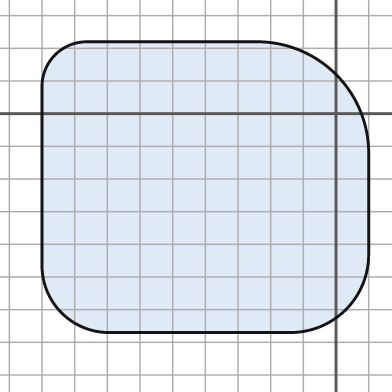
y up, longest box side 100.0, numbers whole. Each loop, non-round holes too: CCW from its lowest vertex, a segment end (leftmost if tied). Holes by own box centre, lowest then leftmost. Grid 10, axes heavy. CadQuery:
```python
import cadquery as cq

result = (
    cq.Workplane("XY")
    .moveTo(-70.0, -67.0)
    .lineTo(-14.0, -67.0)
    .threePointArc((3.0, -60.0), (10.0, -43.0))
    .lineTo(10.0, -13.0)
    .threePointArc((0.0, 12.0), (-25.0, 22.0))
    .lineTo(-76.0, 22.0)
    .threePointArc((-86.0, 18.0), (-90.0, 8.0))
    .lineTo(-90.0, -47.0)
    .threePointArc((-84.0, -61.0), (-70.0, -67.0))
    .close()
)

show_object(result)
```